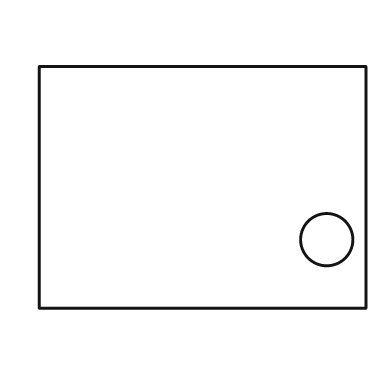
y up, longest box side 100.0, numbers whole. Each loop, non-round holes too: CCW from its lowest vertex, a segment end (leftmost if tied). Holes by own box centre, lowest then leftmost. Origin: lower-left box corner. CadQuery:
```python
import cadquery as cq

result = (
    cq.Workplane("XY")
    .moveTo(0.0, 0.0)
    .lineTo(100.0, 0.0)
    .lineTo(100.0, 74.0)
    .lineTo(0.0, 74.0)
    .close()
    .moveTo(88.0, 21.0)
    .circle(8.0)
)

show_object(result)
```